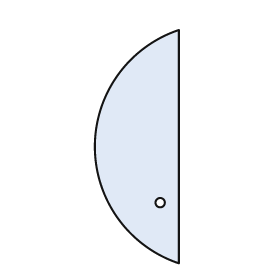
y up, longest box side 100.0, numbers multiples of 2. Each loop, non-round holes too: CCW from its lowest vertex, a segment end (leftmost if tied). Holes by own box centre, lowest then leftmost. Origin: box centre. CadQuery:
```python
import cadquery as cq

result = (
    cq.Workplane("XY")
    .moveTo(18.0, -50.0)
    .lineTo(18.0, 50.0)
    .threePointArc((-18.0, 0.0), (18.0, -50.0))
    .close()
    .moveTo(10.0, -24.0)
    .circle(2.0)
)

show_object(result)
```